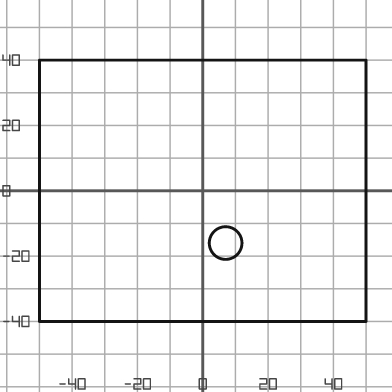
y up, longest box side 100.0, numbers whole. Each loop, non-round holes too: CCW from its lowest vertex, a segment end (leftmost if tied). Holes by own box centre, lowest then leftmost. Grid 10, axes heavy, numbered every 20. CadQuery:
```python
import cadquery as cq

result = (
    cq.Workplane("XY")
    .moveTo(-50.0, -40.0)
    .lineTo(50.0, -40.0)
    .lineTo(50.0, 40.0)
    .lineTo(-50.0, 40.0)
    .close()
    .moveTo(7.0, -16.0)
    .circle(5.0)
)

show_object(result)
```